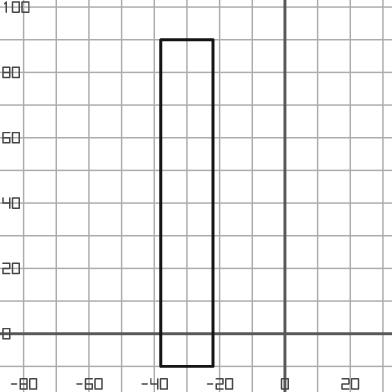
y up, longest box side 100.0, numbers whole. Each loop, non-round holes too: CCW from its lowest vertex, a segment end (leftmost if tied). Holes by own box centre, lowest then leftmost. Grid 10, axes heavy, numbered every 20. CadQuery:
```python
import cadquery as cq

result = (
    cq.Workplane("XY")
    .moveTo(-38.0, -10.0)
    .lineTo(-22.0, -10.0)
    .lineTo(-22.0, 90.0)
    .lineTo(-38.0, 90.0)
    .close()
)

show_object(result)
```